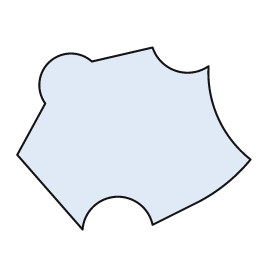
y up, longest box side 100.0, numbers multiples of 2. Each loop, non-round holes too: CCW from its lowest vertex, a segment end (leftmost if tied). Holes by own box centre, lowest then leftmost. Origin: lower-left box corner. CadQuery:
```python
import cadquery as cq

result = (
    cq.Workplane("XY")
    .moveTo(28.0, 0.0)
    .threePointArc((42.0, 14.0), (58.0, 2.0))
    .lineTo(78.0, 12.0)
    .threePointArc((90.0, 20.0), (100.0, 30.0))
    .threePointArc((86.0, 48.0), (82.0, 70.0))
    .threePointArc((68.0, 68.0), (58.0, 78.0))
    .lineTo(32.0, 72.0)
    .threePointArc((14.0, 72.0), (12.0, 54.0))
    .lineTo(0.0, 32.0)
    .close()
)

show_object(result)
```